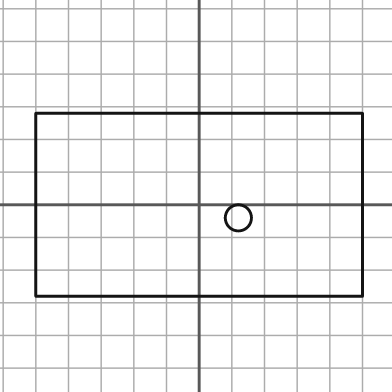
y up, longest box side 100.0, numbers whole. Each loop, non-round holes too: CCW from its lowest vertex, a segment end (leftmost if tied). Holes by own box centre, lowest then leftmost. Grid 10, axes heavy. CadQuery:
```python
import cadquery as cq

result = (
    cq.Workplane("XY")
    .moveTo(-50.0, -28.0)
    .lineTo(50.0, -28.0)
    .lineTo(50.0, 28.0)
    .lineTo(-50.0, 28.0)
    .close()
    .moveTo(12.0, -4.0)
    .circle(4.0)
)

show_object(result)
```